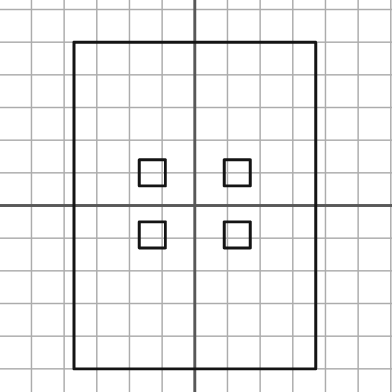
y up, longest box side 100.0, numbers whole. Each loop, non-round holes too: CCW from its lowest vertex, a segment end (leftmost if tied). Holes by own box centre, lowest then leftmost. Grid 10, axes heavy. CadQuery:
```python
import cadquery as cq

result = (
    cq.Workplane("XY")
    .moveTo(-37.0, -50.0)
    .lineTo(37.0, -50.0)
    .lineTo(37.0, 50.0)
    .lineTo(-37.0, 50.0)
    .close()
    .moveTo(-17.0, -13.0)
    .lineTo(-9.0, -13.0)
    .lineTo(-9.0, -5.0)
    .lineTo(-17.0, -5.0)
    .close()
    .moveTo(9.0, -13.0)
    .lineTo(17.0, -13.0)
    .lineTo(17.0, -5.0)
    .lineTo(9.0, -5.0)
    .close()
    .moveTo(-17.0, 6.0)
    .lineTo(-9.0, 6.0)
    .lineTo(-9.0, 14.0)
    .lineTo(-17.0, 14.0)
    .close()
    .moveTo(9.0, 6.0)
    .lineTo(17.0, 6.0)
    .lineTo(17.0, 14.0)
    .lineTo(9.0, 14.0)
    .close()
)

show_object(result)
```